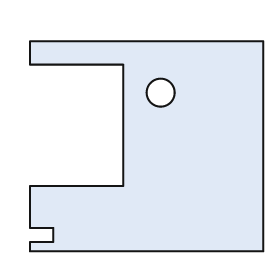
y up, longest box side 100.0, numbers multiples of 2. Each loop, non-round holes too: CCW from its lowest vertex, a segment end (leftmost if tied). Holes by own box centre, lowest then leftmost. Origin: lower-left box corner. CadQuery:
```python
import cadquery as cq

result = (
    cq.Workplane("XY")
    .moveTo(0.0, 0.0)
    .lineTo(100.0, 0.0)
    .lineTo(100.0, 90.0)
    .lineTo(0.0, 90.0)
    .lineTo(0.0, 80.0)
    .lineTo(40.0, 80.0)
    .lineTo(40.0, 28.0)
    .lineTo(0.0, 28.0)
    .lineTo(0.0, 10.0)
    .lineTo(10.0, 10.0)
    .lineTo(10.0, 4.0)
    .lineTo(0.0, 4.0)
    .close()
    .moveTo(56.0, 68.0)
    .circle(6.0)
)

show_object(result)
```